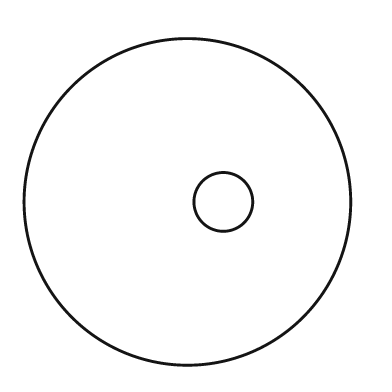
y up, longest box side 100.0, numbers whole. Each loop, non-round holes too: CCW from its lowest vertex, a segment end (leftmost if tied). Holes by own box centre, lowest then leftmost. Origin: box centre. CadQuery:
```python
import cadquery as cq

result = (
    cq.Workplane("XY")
    .moveTo(0.0, 0.0)
    .circle(50.0)
    .moveTo(11.0, 0.0)
    .circle(9.0)
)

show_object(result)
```